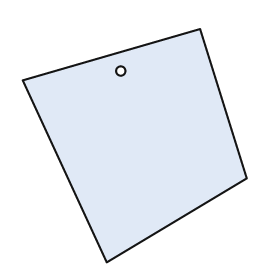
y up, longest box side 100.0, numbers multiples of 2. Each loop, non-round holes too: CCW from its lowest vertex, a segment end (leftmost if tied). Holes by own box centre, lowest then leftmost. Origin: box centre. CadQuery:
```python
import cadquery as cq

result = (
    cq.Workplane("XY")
    .moveTo(-12.0, -50.0)
    .lineTo(48.0, -14.0)
    .lineTo(28.0, 50.0)
    .lineTo(-48.0, 28.0)
    .close()
    .moveTo(-6.0, 32.0)
    .circle(2.0)
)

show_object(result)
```